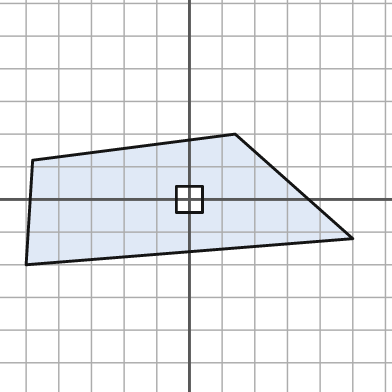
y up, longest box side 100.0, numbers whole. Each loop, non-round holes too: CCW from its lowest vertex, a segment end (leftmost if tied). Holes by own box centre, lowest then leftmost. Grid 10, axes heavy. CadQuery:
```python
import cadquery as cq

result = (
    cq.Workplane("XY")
    .moveTo(-50.0, -20.0)
    .lineTo(50.0, -12.0)
    .lineTo(14.0, 20.0)
    .lineTo(-48.0, 12.0)
    .close()
    .moveTo(-4.0, -4.0)
    .lineTo(4.0, -4.0)
    .lineTo(4.0, 4.0)
    .lineTo(-4.0, 4.0)
    .close()
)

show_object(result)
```